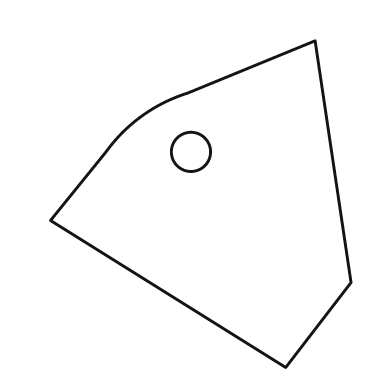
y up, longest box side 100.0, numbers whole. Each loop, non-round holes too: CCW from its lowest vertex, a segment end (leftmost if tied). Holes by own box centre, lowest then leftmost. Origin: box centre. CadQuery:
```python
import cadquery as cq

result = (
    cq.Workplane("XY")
    .moveTo(26.0, -50.0)
    .lineTo(46.0, -24.0)
    .lineTo(35.0, 50.0)
    .lineTo(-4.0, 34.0)
    .threePointArc((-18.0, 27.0), (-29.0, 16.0))
    .lineTo(-46.0, -5.0)
    .close()
    .moveTo(-3.0, 16.0)
    .circle(6.0)
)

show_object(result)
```